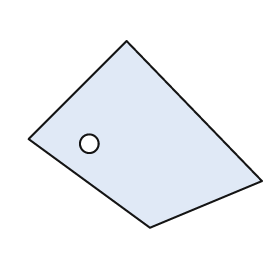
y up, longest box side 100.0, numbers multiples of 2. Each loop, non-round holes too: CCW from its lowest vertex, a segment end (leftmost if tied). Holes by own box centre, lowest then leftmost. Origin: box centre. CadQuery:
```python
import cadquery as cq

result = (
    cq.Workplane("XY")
    .moveTo(2.0, -40.0)
    .lineTo(50.0, -20.0)
    .lineTo(-8.0, 40.0)
    .lineTo(-50.0, -2.0)
    .close()
    .moveTo(-24.0, -4.0)
    .circle(4.0)
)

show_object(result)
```